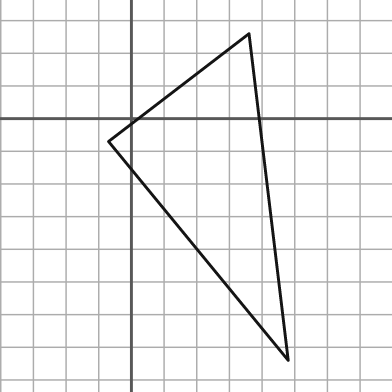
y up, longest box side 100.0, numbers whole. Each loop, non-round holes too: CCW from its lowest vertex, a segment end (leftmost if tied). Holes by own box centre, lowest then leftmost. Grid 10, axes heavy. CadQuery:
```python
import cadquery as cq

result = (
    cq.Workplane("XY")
    .moveTo(48.0, -74.0)
    .lineTo(36.0, 26.0)
    .lineTo(-7.0, -7.0)
    .close()
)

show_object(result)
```